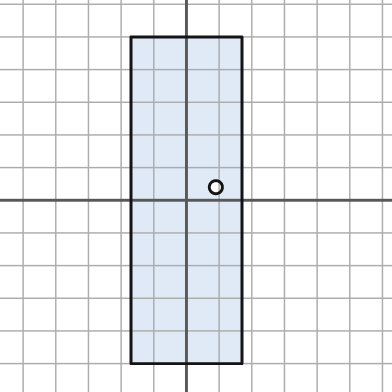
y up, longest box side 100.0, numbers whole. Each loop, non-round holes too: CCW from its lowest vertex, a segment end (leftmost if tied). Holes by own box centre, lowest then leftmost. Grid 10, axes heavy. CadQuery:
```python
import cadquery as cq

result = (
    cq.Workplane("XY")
    .moveTo(-17.0, -50.0)
    .lineTo(17.0, -50.0)
    .lineTo(17.0, 50.0)
    .lineTo(-17.0, 50.0)
    .close()
    .moveTo(9.0, 4.0)
    .circle(2.0)
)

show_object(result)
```